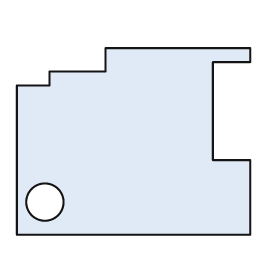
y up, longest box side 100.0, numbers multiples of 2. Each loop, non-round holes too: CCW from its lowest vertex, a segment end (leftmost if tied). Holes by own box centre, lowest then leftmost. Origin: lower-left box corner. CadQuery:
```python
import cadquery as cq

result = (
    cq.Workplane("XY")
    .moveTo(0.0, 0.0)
    .lineTo(100.0, 0.0)
    .lineTo(100.0, 32.0)
    .lineTo(84.0, 32.0)
    .lineTo(84.0, 74.0)
    .lineTo(100.0, 74.0)
    .lineTo(100.0, 80.0)
    .lineTo(38.0, 80.0)
    .lineTo(38.0, 70.0)
    .lineTo(14.0, 70.0)
    .lineTo(14.0, 64.0)
    .lineTo(0.0, 64.0)
    .close()
    .moveTo(12.0, 14.0)
    .circle(8.0)
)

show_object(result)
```